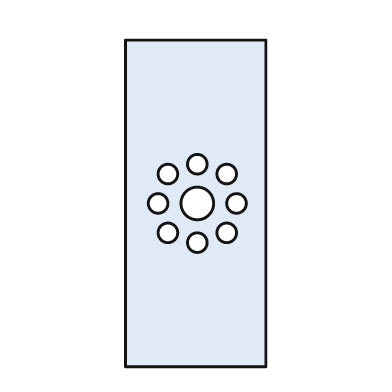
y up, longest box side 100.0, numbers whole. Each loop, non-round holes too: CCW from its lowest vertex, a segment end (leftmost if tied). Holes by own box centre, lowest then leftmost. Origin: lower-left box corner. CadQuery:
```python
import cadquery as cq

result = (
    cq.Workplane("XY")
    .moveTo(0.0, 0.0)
    .lineTo(43.0, 0.0)
    .lineTo(43.0, 100.0)
    .lineTo(0.0, 100.0)
    .close()
    .moveTo(22.0, 38.0)
    .circle(3.0)
    .moveTo(13.0, 41.0)
    .circle(3.0)
    .moveTo(31.0, 41.0)
    .circle(3.0)
    .moveTo(10.0, 50.0)
    .circle(3.0)
    .moveTo(22.0, 50.0)
    .circle(5.0)
    .moveTo(34.0, 50.0)
    .circle(3.0)
    .moveTo(13.0, 59.0)
    .circle(3.0)
    .moveTo(31.0, 59.0)
    .circle(3.0)
    .moveTo(22.0, 62.0)
    .circle(3.0)
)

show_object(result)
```